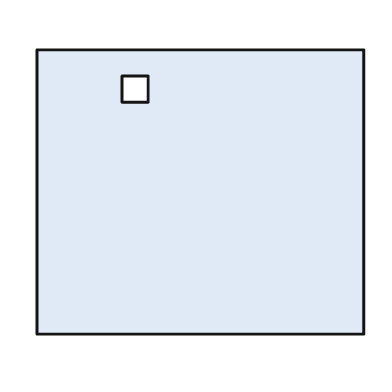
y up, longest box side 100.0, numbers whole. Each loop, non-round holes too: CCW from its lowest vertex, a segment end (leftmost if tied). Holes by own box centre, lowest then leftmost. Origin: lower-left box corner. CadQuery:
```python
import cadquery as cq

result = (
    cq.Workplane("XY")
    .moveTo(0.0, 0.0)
    .lineTo(100.0, 0.0)
    .lineTo(100.0, 87.0)
    .lineTo(0.0, 87.0)
    .close()
    .moveTo(26.0, 71.0)
    .lineTo(34.0, 71.0)
    .lineTo(34.0, 79.0)
    .lineTo(26.0, 79.0)
    .close()
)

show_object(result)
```